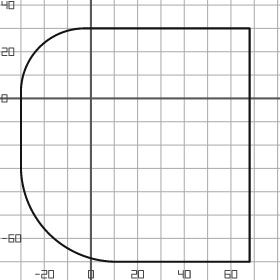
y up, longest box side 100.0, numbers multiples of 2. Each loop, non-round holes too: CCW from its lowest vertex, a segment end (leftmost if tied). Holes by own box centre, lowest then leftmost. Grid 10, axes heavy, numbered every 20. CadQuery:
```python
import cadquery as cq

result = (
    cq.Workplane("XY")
    .moveTo(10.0, -70.0)
    .lineTo(68.0, -70.0)
    .lineTo(68.0, 30.0)
    .lineTo(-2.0, 30.0)
    .threePointArc((-22.0, 22.0), (-30.0, 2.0))
    .lineTo(-30.0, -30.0)
    .threePointArc((-18.0, -58.0), (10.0, -70.0))
    .close()
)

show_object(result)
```